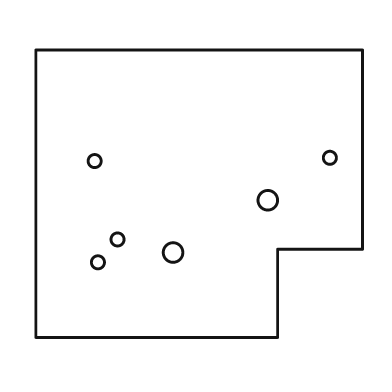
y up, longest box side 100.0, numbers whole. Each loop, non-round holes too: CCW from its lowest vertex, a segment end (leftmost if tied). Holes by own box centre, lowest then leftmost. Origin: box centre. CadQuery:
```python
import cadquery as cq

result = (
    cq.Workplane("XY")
    .moveTo(-50.0, -44.0)
    .lineTo(24.0, -44.0)
    .lineTo(24.0, -17.0)
    .lineTo(50.0, -17.0)
    .lineTo(50.0, 44.0)
    .lineTo(-50.0, 44.0)
    .close()
    .moveTo(-31.0, -21.0)
    .circle(2.0)
    .moveTo(-8.0, -18.0)
    .circle(3.0)
    .moveTo(-25.0, -14.0)
    .circle(2.0)
    .moveTo(21.0, -2.0)
    .circle(3.0)
    .moveTo(-32.0, 10.0)
    .circle(2.0)
    .moveTo(40.0, 11.0)
    .circle(2.0)
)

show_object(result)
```